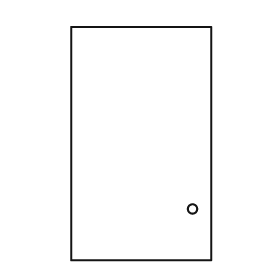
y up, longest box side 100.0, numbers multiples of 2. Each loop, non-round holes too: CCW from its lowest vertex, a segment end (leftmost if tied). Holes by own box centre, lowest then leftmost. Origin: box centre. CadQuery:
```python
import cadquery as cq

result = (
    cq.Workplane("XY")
    .moveTo(-30.0, -50.0)
    .lineTo(30.0, -50.0)
    .lineTo(30.0, 50.0)
    .lineTo(-30.0, 50.0)
    .close()
    .moveTo(22.0, -28.0)
    .circle(2.0)
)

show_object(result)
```